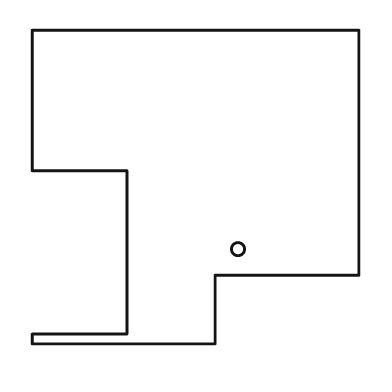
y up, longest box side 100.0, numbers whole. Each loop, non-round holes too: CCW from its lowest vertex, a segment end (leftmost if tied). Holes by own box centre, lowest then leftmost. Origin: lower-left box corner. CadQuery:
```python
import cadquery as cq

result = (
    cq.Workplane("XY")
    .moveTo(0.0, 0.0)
    .lineTo(56.0, 0.0)
    .lineTo(56.0, 21.0)
    .lineTo(100.0, 21.0)
    .lineTo(100.0, 96.0)
    .lineTo(0.0, 96.0)
    .lineTo(0.0, 53.0)
    .lineTo(29.0, 53.0)
    .lineTo(29.0, 3.0)
    .lineTo(0.0, 3.0)
    .close()
    .moveTo(63.0, 29.0)
    .circle(2.0)
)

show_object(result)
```